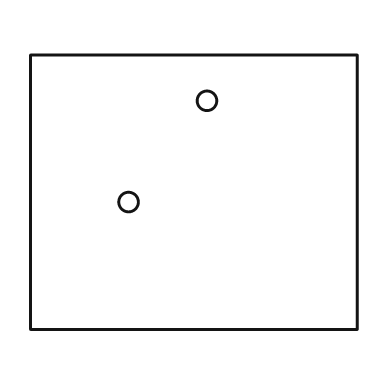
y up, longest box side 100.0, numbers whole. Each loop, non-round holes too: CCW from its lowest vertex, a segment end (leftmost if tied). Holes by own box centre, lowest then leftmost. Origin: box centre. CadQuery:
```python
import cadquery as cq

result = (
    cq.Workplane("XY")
    .moveTo(-50.0, -42.0)
    .lineTo(50.0, -42.0)
    .lineTo(50.0, 42.0)
    .lineTo(-50.0, 42.0)
    .close()
    .moveTo(-20.0, -3.0)
    .circle(3.0)
    .moveTo(4.0, 28.0)
    .circle(3.0)
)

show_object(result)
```